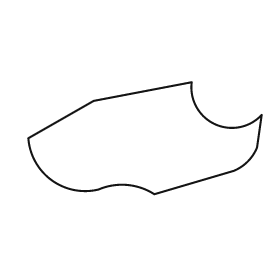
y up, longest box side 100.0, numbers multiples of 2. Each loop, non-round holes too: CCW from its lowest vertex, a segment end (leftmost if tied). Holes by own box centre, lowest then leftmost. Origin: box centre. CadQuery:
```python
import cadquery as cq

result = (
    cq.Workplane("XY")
    .moveTo(4.0, -24.0)
    .lineTo(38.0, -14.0)
    .threePointArc((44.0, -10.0), (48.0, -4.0))
    .lineTo(50.0, 10.0)
    .threePointArc((30.0, 6.0), (20.0, 24.0))
    .lineTo(-22.0, 16.0)
    .lineTo(-50.0, 0.0)
    .threePointArc((-40.0, -18.0), (-20.0, -22.0))
    .threePointArc((-8.0, -20.0), (4.0, -24.0))
    .close()
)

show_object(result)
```